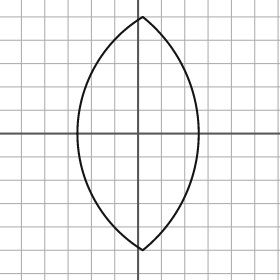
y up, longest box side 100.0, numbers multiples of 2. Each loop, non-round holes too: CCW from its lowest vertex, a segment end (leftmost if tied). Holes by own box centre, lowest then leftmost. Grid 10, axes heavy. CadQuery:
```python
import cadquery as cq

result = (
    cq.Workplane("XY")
    .moveTo(2.0, -50.0)
    .threePointArc((26.0, 0.0), (2.0, 50.0))
    .threePointArc((-26.0, 0.0), (2.0, -50.0))
    .close()
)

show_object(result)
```